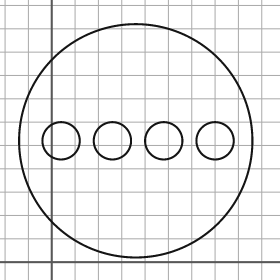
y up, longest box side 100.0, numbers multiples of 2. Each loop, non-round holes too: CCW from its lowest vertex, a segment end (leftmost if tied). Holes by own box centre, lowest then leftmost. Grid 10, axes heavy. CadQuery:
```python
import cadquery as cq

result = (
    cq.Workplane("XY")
    .moveTo(36.0, 52.0)
    .circle(50.0)
    .moveTo(4.0, 52.0)
    .circle(8.0)
    .moveTo(26.0, 52.0)
    .circle(8.0)
    .moveTo(48.0, 52.0)
    .circle(8.0)
    .moveTo(70.0, 52.0)
    .circle(8.0)
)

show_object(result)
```